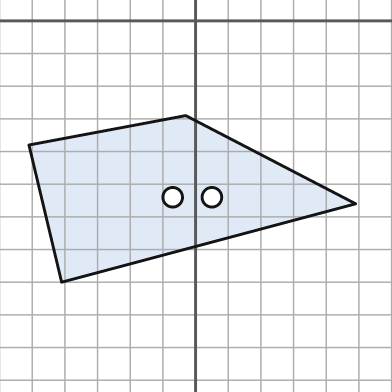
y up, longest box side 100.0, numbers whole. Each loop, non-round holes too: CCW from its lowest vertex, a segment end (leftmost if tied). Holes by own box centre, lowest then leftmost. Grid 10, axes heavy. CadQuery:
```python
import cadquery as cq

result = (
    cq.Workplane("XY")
    .moveTo(-41.0, -80.0)
    .lineTo(49.0, -56.0)
    .lineTo(-3.0, -29.0)
    .lineTo(-51.0, -38.0)
    .close()
    .moveTo(-7.0, -54.0)
    .circle(3.0)
    .moveTo(5.0, -54.0)
    .circle(3.0)
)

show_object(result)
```